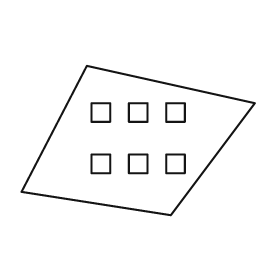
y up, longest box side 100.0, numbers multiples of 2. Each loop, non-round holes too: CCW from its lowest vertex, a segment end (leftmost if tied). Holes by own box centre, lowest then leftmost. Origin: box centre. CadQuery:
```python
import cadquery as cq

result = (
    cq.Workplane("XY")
    .moveTo(14.0, -32.0)
    .lineTo(50.0, 16.0)
    .lineTo(-22.0, 32.0)
    .lineTo(-50.0, -22.0)
    .close()
    .moveTo(-20.0, -14.0)
    .lineTo(-12.0, -14.0)
    .lineTo(-12.0, -6.0)
    .lineTo(-20.0, -6.0)
    .close()
    .moveTo(-4.0, -14.0)
    .lineTo(4.0, -14.0)
    .lineTo(4.0, -6.0)
    .lineTo(-4.0, -6.0)
    .close()
    .moveTo(12.0, -14.0)
    .lineTo(20.0, -14.0)
    .lineTo(20.0, -6.0)
    .lineTo(12.0, -6.0)
    .close()
    .moveTo(-20.0, 8.0)
    .lineTo(-12.0, 8.0)
    .lineTo(-12.0, 16.0)
    .lineTo(-20.0, 16.0)
    .close()
    .moveTo(-4.0, 8.0)
    .lineTo(4.0, 8.0)
    .lineTo(4.0, 16.0)
    .lineTo(-4.0, 16.0)
    .close()
    .moveTo(12.0, 8.0)
    .lineTo(20.0, 8.0)
    .lineTo(20.0, 16.0)
    .lineTo(12.0, 16.0)
    .close()
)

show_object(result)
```